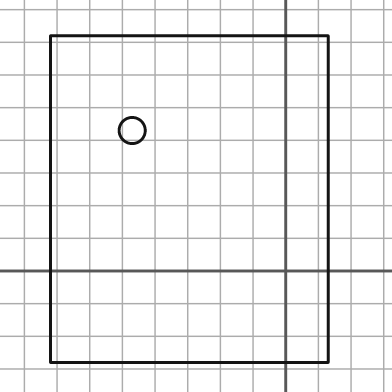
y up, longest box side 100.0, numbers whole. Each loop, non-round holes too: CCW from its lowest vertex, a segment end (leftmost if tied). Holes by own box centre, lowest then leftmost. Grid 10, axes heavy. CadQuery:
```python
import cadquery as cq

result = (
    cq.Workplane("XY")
    .moveTo(-72.0, -28.0)
    .lineTo(13.0, -28.0)
    .lineTo(13.0, 72.0)
    .lineTo(-72.0, 72.0)
    .close()
    .moveTo(-47.0, 43.0)
    .circle(4.0)
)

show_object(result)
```